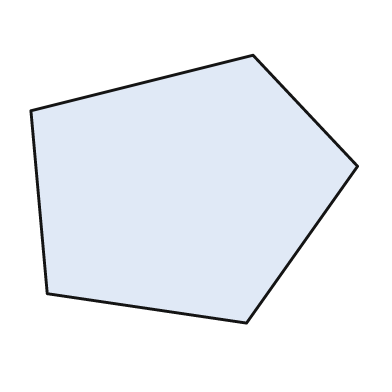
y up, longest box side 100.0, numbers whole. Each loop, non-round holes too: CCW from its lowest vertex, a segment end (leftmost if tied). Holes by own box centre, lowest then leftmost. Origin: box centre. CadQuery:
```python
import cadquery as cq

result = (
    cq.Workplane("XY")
    .moveTo(16.0, -41.0)
    .lineTo(50.0, 7.0)
    .lineTo(18.0, 41.0)
    .lineTo(-50.0, 24.0)
    .lineTo(-45.0, -32.0)
    .close()
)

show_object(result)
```